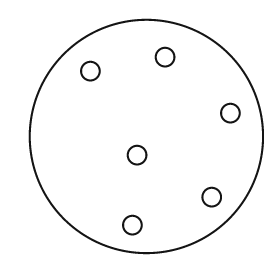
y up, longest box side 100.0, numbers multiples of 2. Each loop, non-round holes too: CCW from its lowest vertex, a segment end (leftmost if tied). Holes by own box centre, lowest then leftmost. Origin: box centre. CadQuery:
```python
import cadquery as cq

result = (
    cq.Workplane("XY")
    .moveTo(0.0, 0.0)
    .circle(50.0)
    .moveTo(-6.0, -38.0)
    .circle(4.0)
    .moveTo(28.0, -26.0)
    .circle(4.0)
    .moveTo(-4.0, -8.0)
    .circle(4.0)
    .moveTo(36.0, 10.0)
    .circle(4.0)
    .moveTo(-24.0, 28.0)
    .circle(4.0)
    .moveTo(8.0, 34.0)
    .circle(4.0)
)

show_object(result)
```